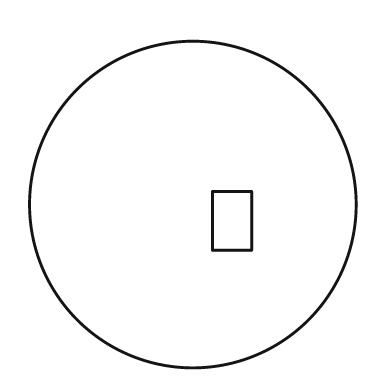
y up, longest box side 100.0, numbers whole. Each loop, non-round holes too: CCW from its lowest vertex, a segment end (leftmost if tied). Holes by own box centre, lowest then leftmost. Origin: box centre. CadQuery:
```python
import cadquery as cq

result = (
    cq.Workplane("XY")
    .moveTo(0.0, 0.0)
    .circle(50.0)
    .moveTo(6.0, -14.0)
    .lineTo(18.0, -14.0)
    .lineTo(18.0, 4.0)
    .lineTo(6.0, 4.0)
    .close()
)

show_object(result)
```